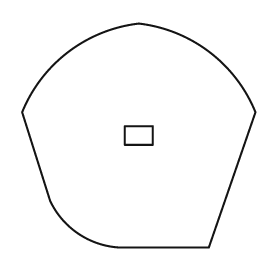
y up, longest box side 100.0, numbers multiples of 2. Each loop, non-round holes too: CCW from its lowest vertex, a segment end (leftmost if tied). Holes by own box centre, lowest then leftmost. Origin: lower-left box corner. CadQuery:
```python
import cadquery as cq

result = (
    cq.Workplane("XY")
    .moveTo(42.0, 0.0)
    .lineTo(80.0, 0.0)
    .lineTo(100.0, 58.0)
    .threePointArc((80.0, 84.0), (50.0, 96.0))
    .threePointArc((20.0, 84.0), (0.0, 58.0))
    .lineTo(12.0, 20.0)
    .threePointArc((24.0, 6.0), (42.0, 0.0))
    .close()
    .moveTo(44.0, 44.0)
    .lineTo(56.0, 44.0)
    .lineTo(56.0, 52.0)
    .lineTo(44.0, 52.0)
    .close()
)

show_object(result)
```